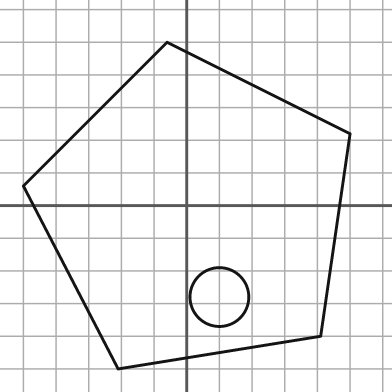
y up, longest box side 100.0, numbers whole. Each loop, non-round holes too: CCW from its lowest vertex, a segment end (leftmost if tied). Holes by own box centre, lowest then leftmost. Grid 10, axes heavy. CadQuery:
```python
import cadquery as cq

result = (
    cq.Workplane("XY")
    .moveTo(-21.0, -50.0)
    .lineTo(41.0, -40.0)
    .lineTo(50.0, 22.0)
    .lineTo(-6.0, 50.0)
    .lineTo(-50.0, 6.0)
    .close()
    .moveTo(10.0, -28.0)
    .circle(9.0)
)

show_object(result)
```